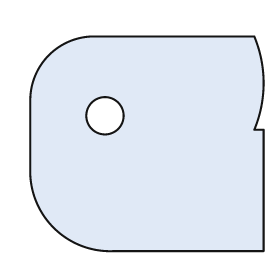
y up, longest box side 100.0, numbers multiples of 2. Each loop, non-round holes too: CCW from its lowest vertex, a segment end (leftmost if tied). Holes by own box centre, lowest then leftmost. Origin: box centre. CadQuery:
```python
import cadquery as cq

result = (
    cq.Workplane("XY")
    .moveTo(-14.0, -46.0)
    .lineTo(50.0, -46.0)
    .lineTo(50.0, 6.0)
    .lineTo(46.0, 6.0)
    .threePointArc((50.0, 26.0), (46.0, 46.0))
    .lineTo(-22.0, 46.0)
    .threePointArc((-42.0, 38.0), (-50.0, 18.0))
    .lineTo(-50.0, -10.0)
    .threePointArc((-40.0, -36.0), (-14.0, -46.0))
    .close()
    .moveTo(-18.0, 12.0)
    .circle(8.0)
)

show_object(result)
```